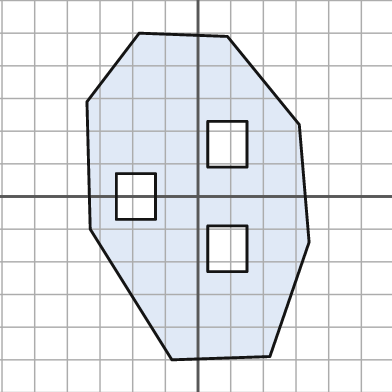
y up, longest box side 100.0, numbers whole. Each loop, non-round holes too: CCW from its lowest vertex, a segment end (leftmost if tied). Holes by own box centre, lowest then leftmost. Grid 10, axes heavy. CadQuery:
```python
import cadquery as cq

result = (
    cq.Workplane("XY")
    .moveTo(-8.0, -50.0)
    .lineTo(22.0, -49.0)
    .lineTo(34.0, -14.0)
    .lineTo(31.0, 22.0)
    .lineTo(9.0, 49.0)
    .lineTo(-18.0, 50.0)
    .lineTo(-34.0, 29.0)
    .lineTo(-33.0, -10.0)
    .close()
    .moveTo(3.0, -23.0)
    .lineTo(15.0, -23.0)
    .lineTo(15.0, -9.0)
    .lineTo(3.0, -9.0)
    .close()
    .moveTo(-25.0, -7.0)
    .lineTo(-13.0, -7.0)
    .lineTo(-13.0, 7.0)
    .lineTo(-25.0, 7.0)
    .close()
    .moveTo(3.0, 9.0)
    .lineTo(15.0, 9.0)
    .lineTo(15.0, 23.0)
    .lineTo(3.0, 23.0)
    .close()
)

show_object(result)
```